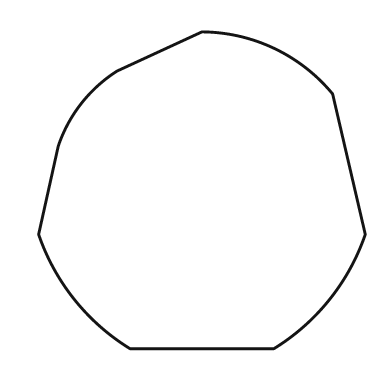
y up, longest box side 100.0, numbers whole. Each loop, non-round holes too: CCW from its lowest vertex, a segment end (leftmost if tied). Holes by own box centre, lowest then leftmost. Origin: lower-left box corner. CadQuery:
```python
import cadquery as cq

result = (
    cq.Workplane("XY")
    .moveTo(28.0, 0.0)
    .lineTo(72.0, 0.0)
    .threePointArc((89.0, 15.0), (100.0, 35.0))
    .lineTo(90.0, 78.0)
    .threePointArc((72.0, 92.0), (50.0, 97.0))
    .lineTo(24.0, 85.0)
    .threePointArc((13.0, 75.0), (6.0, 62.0))
    .lineTo(0.0, 35.0)
    .threePointArc((11.0, 15.0), (28.0, 0.0))
    .close()
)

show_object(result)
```